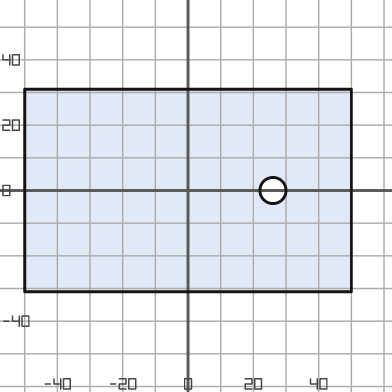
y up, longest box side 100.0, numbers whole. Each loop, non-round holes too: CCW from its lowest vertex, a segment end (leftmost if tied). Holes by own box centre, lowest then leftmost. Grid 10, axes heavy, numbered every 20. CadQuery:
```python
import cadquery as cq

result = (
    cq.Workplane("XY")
    .moveTo(-50.0, -31.0)
    .lineTo(50.0, -31.0)
    .lineTo(50.0, 31.0)
    .lineTo(-50.0, 31.0)
    .close()
    .moveTo(26.0, 0.0)
    .circle(4.0)
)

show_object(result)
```